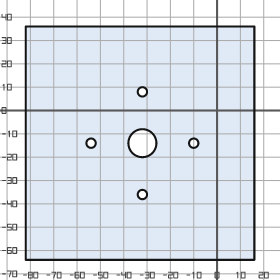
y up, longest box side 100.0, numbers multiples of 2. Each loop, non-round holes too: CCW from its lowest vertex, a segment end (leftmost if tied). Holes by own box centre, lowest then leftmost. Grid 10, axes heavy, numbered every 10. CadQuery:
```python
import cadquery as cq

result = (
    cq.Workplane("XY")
    .moveTo(-82.0, -64.0)
    .lineTo(16.0, -64.0)
    .lineTo(16.0, 36.0)
    .lineTo(-82.0, 36.0)
    .close()
    .moveTo(-32.0, -36.0)
    .circle(2.0)
    .moveTo(-54.0, -14.0)
    .circle(2.0)
    .moveTo(-32.0, -14.0)
    .circle(6.0)
    .moveTo(-10.0, -14.0)
    .circle(2.0)
    .moveTo(-32.0, 8.0)
    .circle(2.0)
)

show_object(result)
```